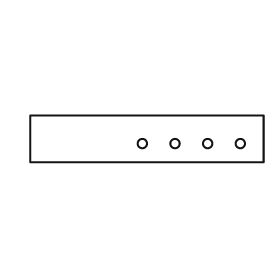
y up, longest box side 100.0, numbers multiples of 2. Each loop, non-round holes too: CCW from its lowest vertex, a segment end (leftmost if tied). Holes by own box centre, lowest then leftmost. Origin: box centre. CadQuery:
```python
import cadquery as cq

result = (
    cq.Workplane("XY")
    .moveTo(-50.0, -10.0)
    .lineTo(50.0, -10.0)
    .lineTo(50.0, 10.0)
    .lineTo(-50.0, 10.0)
    .close()
    .moveTo(-2.0, -2.0)
    .circle(2.0)
    .moveTo(12.0, -2.0)
    .circle(2.0)
    .moveTo(26.0, -2.0)
    .circle(2.0)
    .moveTo(40.0, -2.0)
    .circle(2.0)
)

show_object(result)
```